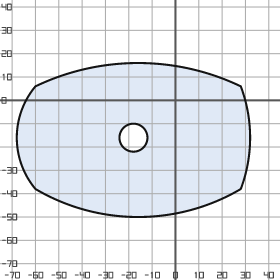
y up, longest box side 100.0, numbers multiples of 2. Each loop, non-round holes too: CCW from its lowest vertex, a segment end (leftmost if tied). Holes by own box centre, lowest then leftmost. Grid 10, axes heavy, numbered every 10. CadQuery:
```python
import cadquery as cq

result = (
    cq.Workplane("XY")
    .moveTo(-60.0, -38.0)
    .threePointArc((-16.0, -50.0), (28.0, -38.0))
    .threePointArc((32.0, -16.0), (28.0, 6.0))
    .threePointArc((-16.0, 16.0), (-60.0, 6.0))
    .threePointArc((-68.0, -16.0), (-60.0, -38.0))
    .close()
    .moveTo(-18.0, -16.0)
    .circle(6.0)
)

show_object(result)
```